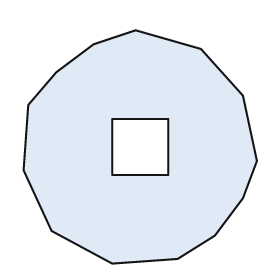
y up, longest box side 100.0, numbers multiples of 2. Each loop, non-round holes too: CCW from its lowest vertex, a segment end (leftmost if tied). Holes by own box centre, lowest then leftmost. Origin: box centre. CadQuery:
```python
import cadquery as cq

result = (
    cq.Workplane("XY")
    .moveTo(-12.0, -50.0)
    .lineTo(16.0, -48.0)
    .lineTo(32.0, -38.0)
    .lineTo(44.0, -22.0)
    .lineTo(50.0, -6.0)
    .lineTo(44.0, 22.0)
    .lineTo(26.0, 42.0)
    .lineTo(-2.0, 50.0)
    .lineTo(-20.0, 44.0)
    .lineTo(-36.0, 32.0)
    .lineTo(-48.0, 18.0)
    .lineTo(-50.0, -10.0)
    .lineTo(-38.0, -36.0)
    .close()
    .moveTo(-12.0, -12.0)
    .lineTo(12.0, -12.0)
    .lineTo(12.0, 12.0)
    .lineTo(-12.0, 12.0)
    .close()
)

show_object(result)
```